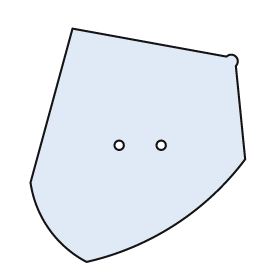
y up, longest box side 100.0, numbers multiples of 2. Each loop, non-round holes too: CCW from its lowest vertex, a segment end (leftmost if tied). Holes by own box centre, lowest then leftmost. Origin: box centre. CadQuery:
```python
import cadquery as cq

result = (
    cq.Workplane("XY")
    .moveTo(-22.0, -50.0)
    .threePointArc((16.0, -34.0), (46.0, -6.0))
    .lineTo(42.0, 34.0)
    .threePointArc((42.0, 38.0), (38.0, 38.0))
    .lineTo(-28.0, 50.0)
    .lineTo(-46.0, -16.0)
    .threePointArc((-38.0, -36.0), (-22.0, -50.0))
    .close()
    .moveTo(-8.0, 0.0)
    .circle(2.0)
    .moveTo(10.0, 0.0)
    .circle(2.0)
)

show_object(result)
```